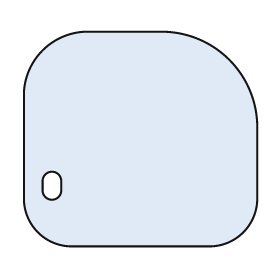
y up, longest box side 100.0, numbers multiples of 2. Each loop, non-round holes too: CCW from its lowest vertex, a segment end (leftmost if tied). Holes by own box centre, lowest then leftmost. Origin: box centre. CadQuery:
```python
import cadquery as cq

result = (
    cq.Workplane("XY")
    .moveTo(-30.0, -46.0)
    .lineTo(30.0, -46.0)
    .threePointArc((44.0, -40.0), (50.0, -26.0))
    .lineTo(50.0, 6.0)
    .threePointArc((38.0, 34.0), (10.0, 46.0))
    .lineTo(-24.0, 46.0)
    .threePointArc((-42.0, 38.0), (-50.0, 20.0))
    .lineTo(-50.0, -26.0)
    .threePointArc((-44.0, -40.0), (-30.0, -46.0))
    .close()
    .moveTo(-42.0, -22.0)
    .threePointArc((-38.0, -26.0), (-34.0, -22.0))
    .lineTo(-34.0, -18.0)
    .threePointArc((-38.0, -14.0), (-42.0, -18.0))
    .close()
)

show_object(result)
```